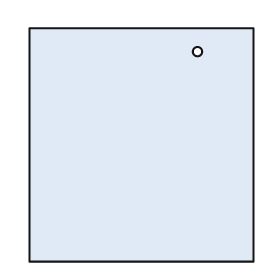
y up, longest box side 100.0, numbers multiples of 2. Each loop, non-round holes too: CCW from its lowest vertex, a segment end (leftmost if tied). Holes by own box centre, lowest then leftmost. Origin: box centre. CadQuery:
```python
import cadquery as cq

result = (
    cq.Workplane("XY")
    .moveTo(-48.0, -50.0)
    .lineTo(48.0, -50.0)
    .lineTo(48.0, 50.0)
    .lineTo(-48.0, 50.0)
    .close()
    .moveTo(24.0, 40.0)
    .circle(2.0)
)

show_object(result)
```